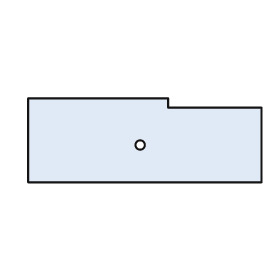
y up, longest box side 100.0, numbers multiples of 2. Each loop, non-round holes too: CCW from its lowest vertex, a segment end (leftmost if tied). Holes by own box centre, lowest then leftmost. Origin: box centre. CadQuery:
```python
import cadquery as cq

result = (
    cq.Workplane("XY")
    .moveTo(-50.0, -18.0)
    .lineTo(50.0, -18.0)
    .lineTo(50.0, 14.0)
    .lineTo(10.0, 14.0)
    .lineTo(10.0, 18.0)
    .lineTo(-50.0, 18.0)
    .close()
    .moveTo(-2.0, -2.0)
    .circle(2.0)
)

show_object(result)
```